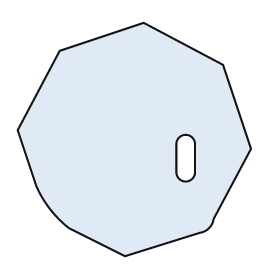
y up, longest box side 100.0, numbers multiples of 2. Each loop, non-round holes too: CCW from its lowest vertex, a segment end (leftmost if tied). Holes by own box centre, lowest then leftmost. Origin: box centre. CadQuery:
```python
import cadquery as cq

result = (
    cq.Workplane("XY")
    .moveTo(-4.0, -50.0)
    .lineTo(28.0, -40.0)
    .threePointArc((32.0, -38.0), (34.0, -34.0))
    .lineTo(50.0, -4.0)
    .lineTo(38.0, 32.0)
    .lineTo(4.0, 50.0)
    .lineTo(-32.0, 38.0)
    .lineTo(-50.0, 4.0)
    .lineTo(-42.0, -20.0)
    .threePointArc((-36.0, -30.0), (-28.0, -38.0))
    .close()
    .moveTo(18.0, -14.0)
    .threePointArc((22.0, -18.0), (26.0, -14.0))
    .lineTo(26.0, -2.0)
    .threePointArc((22.0, 2.0), (18.0, -2.0))
    .close()
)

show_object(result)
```